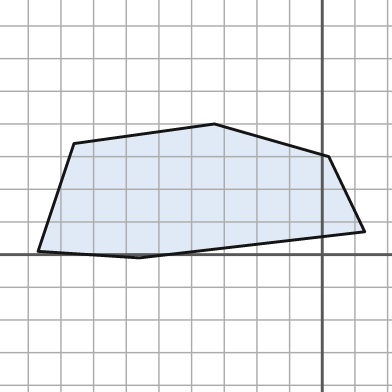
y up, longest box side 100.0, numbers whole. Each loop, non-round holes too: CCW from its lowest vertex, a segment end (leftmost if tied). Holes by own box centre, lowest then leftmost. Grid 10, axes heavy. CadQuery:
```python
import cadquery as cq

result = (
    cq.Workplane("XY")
    .moveTo(-56.0, -1.0)
    .lineTo(13.0, 7.0)
    .lineTo(2.0, 30.0)
    .lineTo(-33.0, 40.0)
    .lineTo(-76.0, 34.0)
    .lineTo(-87.0, 1.0)
    .close()
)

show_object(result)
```